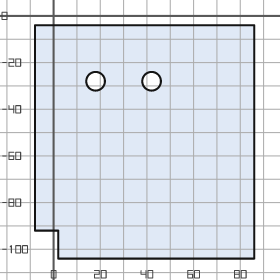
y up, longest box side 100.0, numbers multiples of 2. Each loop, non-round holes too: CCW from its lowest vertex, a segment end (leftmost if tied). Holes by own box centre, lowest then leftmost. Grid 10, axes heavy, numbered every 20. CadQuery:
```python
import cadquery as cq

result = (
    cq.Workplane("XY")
    .moveTo(2.0, -104.0)
    .lineTo(86.0, -104.0)
    .lineTo(86.0, -4.0)
    .lineTo(-8.0, -4.0)
    .lineTo(-8.0, -92.0)
    .lineTo(2.0, -92.0)
    .close()
    .moveTo(18.0, -28.0)
    .circle(4.0)
    .moveTo(42.0, -28.0)
    .circle(4.0)
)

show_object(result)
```